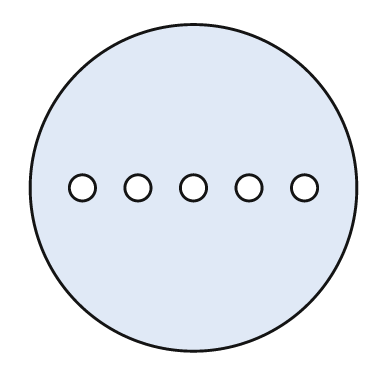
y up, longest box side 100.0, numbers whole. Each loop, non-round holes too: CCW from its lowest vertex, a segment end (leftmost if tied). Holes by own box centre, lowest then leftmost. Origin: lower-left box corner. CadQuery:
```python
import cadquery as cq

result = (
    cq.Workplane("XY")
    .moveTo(50.0, 50.0)
    .circle(50.0)
    .moveTo(16.0, 50.0)
    .circle(4.0)
    .moveTo(33.0, 50.0)
    .circle(4.0)
    .moveTo(50.0, 50.0)
    .circle(4.0)
    .moveTo(67.0, 50.0)
    .circle(4.0)
    .moveTo(84.0, 50.0)
    .circle(4.0)
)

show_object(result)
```